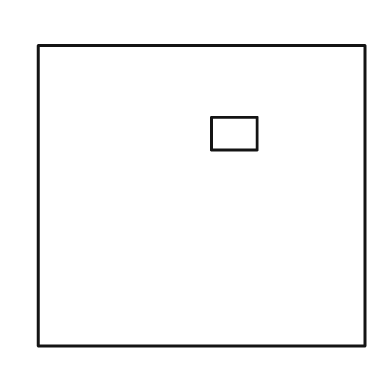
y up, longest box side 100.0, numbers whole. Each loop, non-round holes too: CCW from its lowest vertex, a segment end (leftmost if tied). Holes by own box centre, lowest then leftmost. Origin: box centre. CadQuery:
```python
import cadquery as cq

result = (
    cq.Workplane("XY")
    .moveTo(-50.0, -46.0)
    .lineTo(50.0, -46.0)
    .lineTo(50.0, 46.0)
    .lineTo(-50.0, 46.0)
    .close()
    .moveTo(3.0, 14.0)
    .lineTo(17.0, 14.0)
    .lineTo(17.0, 24.0)
    .lineTo(3.0, 24.0)
    .close()
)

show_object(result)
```